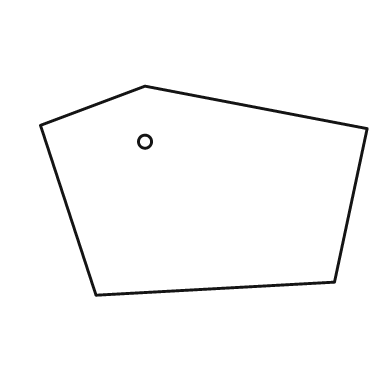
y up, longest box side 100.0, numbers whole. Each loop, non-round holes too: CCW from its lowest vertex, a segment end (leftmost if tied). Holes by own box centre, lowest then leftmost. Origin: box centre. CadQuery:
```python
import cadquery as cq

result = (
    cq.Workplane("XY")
    .moveTo(-33.0, -32.0)
    .lineTo(40.0, -28.0)
    .lineTo(50.0, 19.0)
    .lineTo(-18.0, 32.0)
    .lineTo(-50.0, 20.0)
    .close()
    .moveTo(-18.0, 15.0)
    .circle(2.0)
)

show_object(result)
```